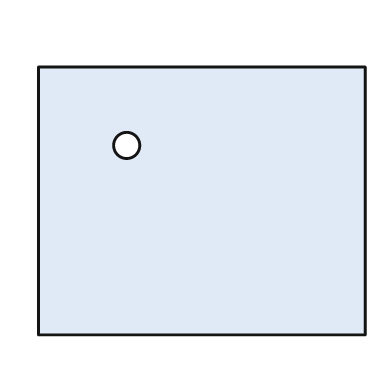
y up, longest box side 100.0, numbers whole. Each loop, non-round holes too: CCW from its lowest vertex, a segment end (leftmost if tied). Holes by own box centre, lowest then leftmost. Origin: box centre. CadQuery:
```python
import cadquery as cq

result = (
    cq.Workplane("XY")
    .moveTo(-50.0, -41.0)
    .lineTo(50.0, -41.0)
    .lineTo(50.0, 41.0)
    .lineTo(-50.0, 41.0)
    .close()
    .moveTo(-23.0, 17.0)
    .circle(4.0)
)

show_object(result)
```